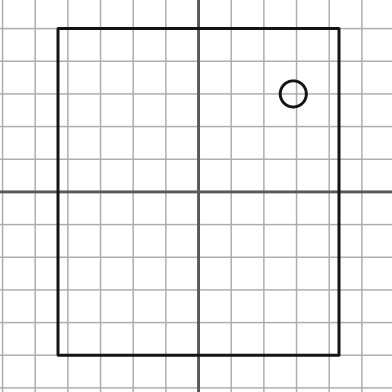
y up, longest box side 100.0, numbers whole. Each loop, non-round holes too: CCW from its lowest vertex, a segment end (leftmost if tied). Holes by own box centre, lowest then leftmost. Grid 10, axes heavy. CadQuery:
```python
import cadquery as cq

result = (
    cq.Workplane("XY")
    .moveTo(-43.0, -50.0)
    .lineTo(43.0, -50.0)
    .lineTo(43.0, 50.0)
    .lineTo(-43.0, 50.0)
    .close()
    .moveTo(29.0, 30.0)
    .circle(4.0)
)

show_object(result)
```